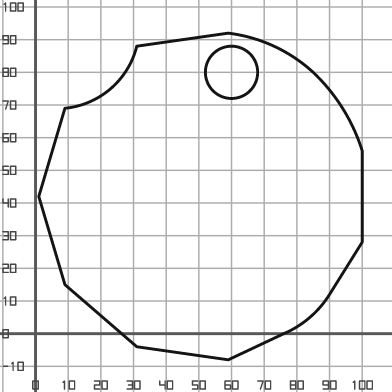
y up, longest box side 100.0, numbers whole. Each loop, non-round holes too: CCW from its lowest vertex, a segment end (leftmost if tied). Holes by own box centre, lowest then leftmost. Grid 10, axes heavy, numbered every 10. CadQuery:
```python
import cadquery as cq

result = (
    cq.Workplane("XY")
    .moveTo(59.0, -8.0)
    .lineTo(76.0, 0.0)
    .threePointArc((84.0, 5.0), (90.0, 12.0))
    .lineTo(100.0, 28.0)
    .lineTo(100.0, 56.0)
    .threePointArc((94.0, 69.0), (85.0, 80.0))
    .threePointArc((73.0, 88.0), (59.0, 92.0))
    .lineTo(31.0, 88.0)
    .threePointArc((23.0, 75.0), (9.0, 69.0))
    .lineTo(1.0, 42.0)
    .lineTo(9.0, 15.0)
    .lineTo(31.0, -4.0)
    .close()
    .moveTo(60.0, 80.0)
    .circle(8.0)
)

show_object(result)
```